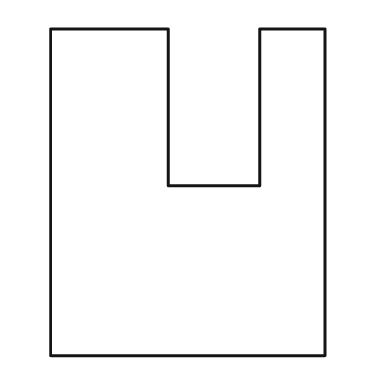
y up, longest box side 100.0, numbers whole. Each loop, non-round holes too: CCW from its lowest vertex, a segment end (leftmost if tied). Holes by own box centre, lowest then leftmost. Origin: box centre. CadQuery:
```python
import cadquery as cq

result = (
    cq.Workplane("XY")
    .moveTo(-42.0, -50.0)
    .lineTo(42.0, -50.0)
    .lineTo(42.0, 50.0)
    .lineTo(22.0, 50.0)
    .lineTo(22.0, 2.0)
    .lineTo(-6.0, 2.0)
    .lineTo(-6.0, 50.0)
    .lineTo(-42.0, 50.0)
    .close()
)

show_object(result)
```